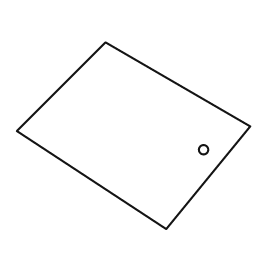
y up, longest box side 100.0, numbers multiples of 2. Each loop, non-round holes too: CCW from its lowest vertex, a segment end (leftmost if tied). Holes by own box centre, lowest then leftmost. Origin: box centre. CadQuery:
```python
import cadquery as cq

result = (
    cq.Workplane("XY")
    .moveTo(14.0, -40.0)
    .lineTo(50.0, 4.0)
    .lineTo(-12.0, 40.0)
    .lineTo(-50.0, 2.0)
    .close()
    .moveTo(30.0, -6.0)
    .circle(2.0)
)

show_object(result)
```